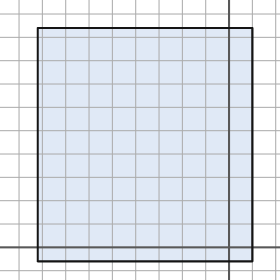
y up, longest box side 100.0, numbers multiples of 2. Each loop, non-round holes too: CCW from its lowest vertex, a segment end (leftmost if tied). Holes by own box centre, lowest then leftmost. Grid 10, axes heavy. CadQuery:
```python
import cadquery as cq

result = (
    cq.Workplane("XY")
    .moveTo(-82.0, -6.0)
    .lineTo(10.0, -6.0)
    .lineTo(10.0, 94.0)
    .lineTo(-82.0, 94.0)
    .close()
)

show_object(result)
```